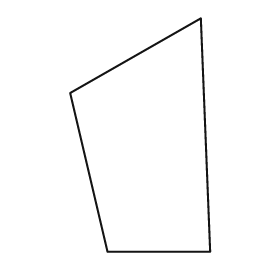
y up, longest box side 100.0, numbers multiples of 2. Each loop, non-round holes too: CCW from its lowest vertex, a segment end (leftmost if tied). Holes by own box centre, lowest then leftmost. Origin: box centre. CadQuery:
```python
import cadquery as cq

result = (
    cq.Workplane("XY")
    .moveTo(-14.0, -50.0)
    .lineTo(30.0, -50.0)
    .lineTo(26.0, 50.0)
    .lineTo(-30.0, 18.0)
    .close()
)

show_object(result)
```